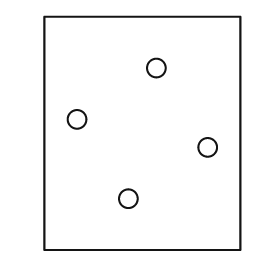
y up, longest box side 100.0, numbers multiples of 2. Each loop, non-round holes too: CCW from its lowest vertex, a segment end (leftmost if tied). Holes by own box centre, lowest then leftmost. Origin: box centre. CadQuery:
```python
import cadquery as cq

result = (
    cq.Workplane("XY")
    .moveTo(-42.0, -50.0)
    .lineTo(42.0, -50.0)
    .lineTo(42.0, 50.0)
    .lineTo(-42.0, 50.0)
    .close()
    .moveTo(-6.0, -28.0)
    .circle(4.0)
    .moveTo(28.0, -6.0)
    .circle(4.0)
    .moveTo(-28.0, 6.0)
    .circle(4.0)
    .moveTo(6.0, 28.0)
    .circle(4.0)
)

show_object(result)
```